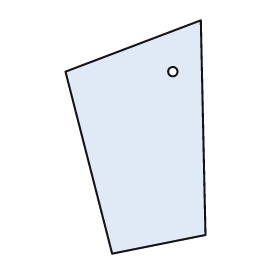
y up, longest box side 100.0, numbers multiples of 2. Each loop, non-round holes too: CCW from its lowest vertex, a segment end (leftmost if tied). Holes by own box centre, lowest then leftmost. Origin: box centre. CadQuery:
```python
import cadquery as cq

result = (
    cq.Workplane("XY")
    .moveTo(-10.0, -50.0)
    .lineTo(30.0, -42.0)
    .lineTo(28.0, 50.0)
    .lineTo(-30.0, 28.0)
    .close()
    .moveTo(16.0, 28.0)
    .circle(2.0)
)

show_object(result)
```